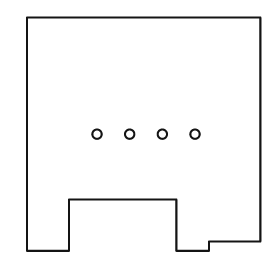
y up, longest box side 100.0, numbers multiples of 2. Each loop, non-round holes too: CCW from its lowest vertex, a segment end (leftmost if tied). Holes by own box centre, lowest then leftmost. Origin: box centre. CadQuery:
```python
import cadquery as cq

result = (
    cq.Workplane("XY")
    .moveTo(-50.0, -50.0)
    .lineTo(-32.0, -50.0)
    .lineTo(-32.0, -28.0)
    .lineTo(14.0, -28.0)
    .lineTo(14.0, -50.0)
    .lineTo(28.0, -50.0)
    .lineTo(28.0, -46.0)
    .lineTo(50.0, -46.0)
    .lineTo(50.0, 50.0)
    .lineTo(-50.0, 50.0)
    .close()
    .moveTo(-20.0, 0.0)
    .circle(2.0)
    .moveTo(-6.0, 0.0)
    .circle(2.0)
    .moveTo(8.0, 0.0)
    .circle(2.0)
    .moveTo(22.0, 0.0)
    .circle(2.0)
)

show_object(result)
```